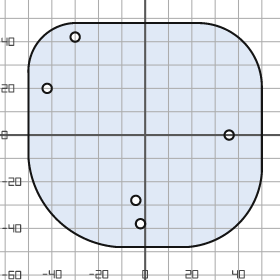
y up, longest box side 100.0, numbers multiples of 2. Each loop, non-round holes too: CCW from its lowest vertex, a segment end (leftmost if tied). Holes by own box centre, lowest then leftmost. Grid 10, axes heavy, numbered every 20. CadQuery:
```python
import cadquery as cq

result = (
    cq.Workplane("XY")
    .moveTo(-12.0, -48.0)
    .lineTo(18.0, -48.0)
    .threePointArc((40.0, -38.0), (50.0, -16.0))
    .lineTo(50.0, 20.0)
    .threePointArc((42.0, 40.0), (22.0, 48.0))
    .lineTo(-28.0, 48.0)
    .threePointArc((-44.0, 42.0), (-50.0, 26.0))
    .lineTo(-50.0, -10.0)
    .threePointArc((-38.0, -36.0), (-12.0, -48.0))
    .close()
    .moveTo(-2.0, -38.0)
    .circle(2.0)
    .moveTo(-4.0, -28.0)
    .circle(2.0)
    .moveTo(36.0, 0.0)
    .circle(2.0)
    .moveTo(-42.0, 20.0)
    .circle(2.0)
    .moveTo(-30.0, 42.0)
    .circle(2.0)
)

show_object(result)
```